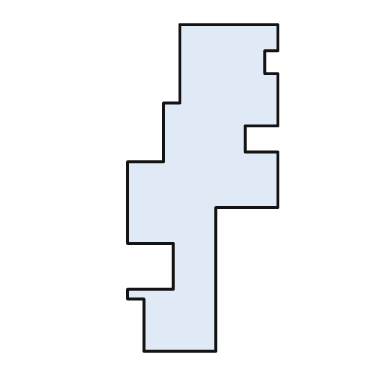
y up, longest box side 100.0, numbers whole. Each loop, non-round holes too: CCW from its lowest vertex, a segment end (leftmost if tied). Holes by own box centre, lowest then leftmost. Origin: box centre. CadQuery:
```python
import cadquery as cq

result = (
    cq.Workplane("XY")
    .moveTo(-18.0, -50.0)
    .lineTo(4.0, -50.0)
    .lineTo(4.0, -6.0)
    .lineTo(23.0, -6.0)
    .lineTo(23.0, 11.0)
    .lineTo(13.0, 11.0)
    .lineTo(13.0, 19.0)
    .lineTo(23.0, 19.0)
    .lineTo(23.0, 35.0)
    .lineTo(19.0, 35.0)
    .lineTo(19.0, 42.0)
    .lineTo(23.0, 42.0)
    .lineTo(23.0, 50.0)
    .lineTo(-7.0, 50.0)
    .lineTo(-7.0, 26.0)
    .lineTo(-12.0, 26.0)
    .lineTo(-12.0, 8.0)
    .lineTo(-23.0, 8.0)
    .lineTo(-23.0, -17.0)
    .lineTo(-9.0, -17.0)
    .lineTo(-9.0, -31.0)
    .lineTo(-23.0, -31.0)
    .lineTo(-23.0, -34.0)
    .lineTo(-18.0, -34.0)
    .close()
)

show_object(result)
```